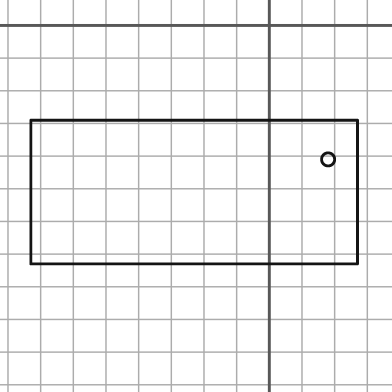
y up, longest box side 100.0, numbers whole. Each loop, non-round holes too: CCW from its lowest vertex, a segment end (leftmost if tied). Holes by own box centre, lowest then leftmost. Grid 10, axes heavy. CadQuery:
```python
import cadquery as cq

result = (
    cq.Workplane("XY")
    .moveTo(-73.0, -73.0)
    .lineTo(27.0, -73.0)
    .lineTo(27.0, -29.0)
    .lineTo(-73.0, -29.0)
    .close()
    .moveTo(18.0, -41.0)
    .circle(2.0)
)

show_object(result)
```